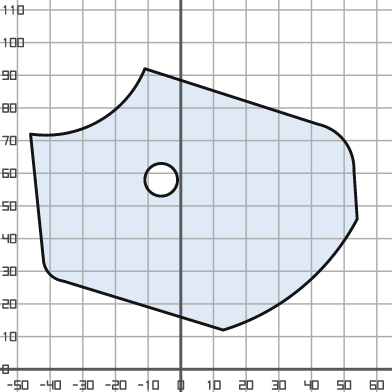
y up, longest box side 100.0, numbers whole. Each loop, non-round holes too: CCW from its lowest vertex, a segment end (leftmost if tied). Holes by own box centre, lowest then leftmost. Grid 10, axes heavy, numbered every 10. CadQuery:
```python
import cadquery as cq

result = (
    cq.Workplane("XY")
    .moveTo(13.0, 12.0)
    .threePointArc((37.0, 25.0), (54.0, 46.0))
    .lineTo(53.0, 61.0)
    .threePointArc((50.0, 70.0), (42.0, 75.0))
    .lineTo(-11.0, 92.0)
    .threePointArc((-25.0, 76.0), (-46.0, 72.0))
    .lineTo(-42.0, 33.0)
    .threePointArc((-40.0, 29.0), (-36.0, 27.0))
    .close()
    .moveTo(-6.0, 58.0)
    .circle(5.0)
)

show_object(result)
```